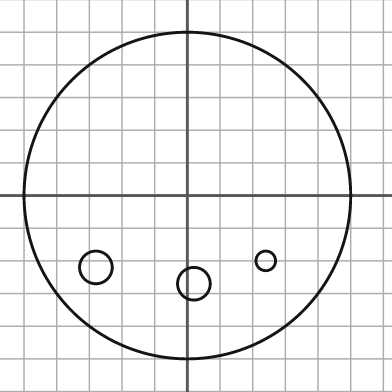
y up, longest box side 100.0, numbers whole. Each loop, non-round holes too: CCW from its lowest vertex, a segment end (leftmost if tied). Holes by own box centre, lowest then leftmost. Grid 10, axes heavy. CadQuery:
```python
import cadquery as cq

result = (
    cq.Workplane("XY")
    .moveTo(0.0, 0.0)
    .circle(50.0)
    .moveTo(2.0, -27.0)
    .circle(5.0)
    .moveTo(-28.0, -22.0)
    .circle(5.0)
    .moveTo(24.0, -20.0)
    .circle(3.0)
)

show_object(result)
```